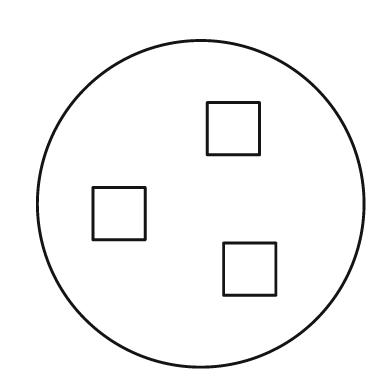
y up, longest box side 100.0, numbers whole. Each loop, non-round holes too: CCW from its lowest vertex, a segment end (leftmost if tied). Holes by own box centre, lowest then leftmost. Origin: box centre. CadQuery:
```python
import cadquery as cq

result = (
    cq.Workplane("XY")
    .moveTo(0.0, 0.0)
    .circle(50.0)
    .moveTo(7.0, -28.0)
    .lineTo(23.0, -28.0)
    .lineTo(23.0, -12.0)
    .lineTo(7.0, -12.0)
    .close()
    .moveTo(-33.0, -11.0)
    .lineTo(-17.0, -11.0)
    .lineTo(-17.0, 5.0)
    .lineTo(-33.0, 5.0)
    .close()
    .moveTo(2.0, 15.0)
    .lineTo(18.0, 15.0)
    .lineTo(18.0, 31.0)
    .lineTo(2.0, 31.0)
    .close()
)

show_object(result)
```